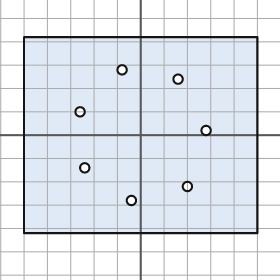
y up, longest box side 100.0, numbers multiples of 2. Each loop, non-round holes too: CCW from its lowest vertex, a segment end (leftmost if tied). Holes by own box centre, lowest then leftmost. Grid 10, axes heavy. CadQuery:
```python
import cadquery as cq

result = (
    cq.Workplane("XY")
    .moveTo(-50.0, -42.0)
    .lineTo(50.0, -42.0)
    .lineTo(50.0, 42.0)
    .lineTo(-50.0, 42.0)
    .close()
    .moveTo(-4.0, -28.0)
    .circle(2.0)
    .moveTo(20.0, -22.0)
    .circle(2.0)
    .moveTo(-24.0, -14.0)
    .circle(2.0)
    .moveTo(28.0, 2.0)
    .circle(2.0)
    .moveTo(-26.0, 10.0)
    .circle(2.0)
    .moveTo(16.0, 24.0)
    .circle(2.0)
    .moveTo(-8.0, 28.0)
    .circle(2.0)
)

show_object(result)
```